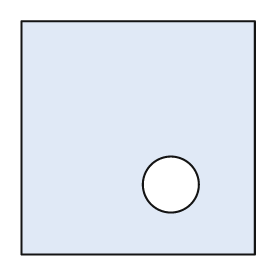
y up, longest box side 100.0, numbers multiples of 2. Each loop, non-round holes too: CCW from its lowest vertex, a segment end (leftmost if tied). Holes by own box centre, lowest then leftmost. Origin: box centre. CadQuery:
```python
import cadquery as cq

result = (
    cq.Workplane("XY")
    .moveTo(-50.0, -50.0)
    .lineTo(50.0, -50.0)
    .lineTo(50.0, 50.0)
    .lineTo(-50.0, 50.0)
    .close()
    .moveTo(14.0, -20.0)
    .circle(12.0)
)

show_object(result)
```